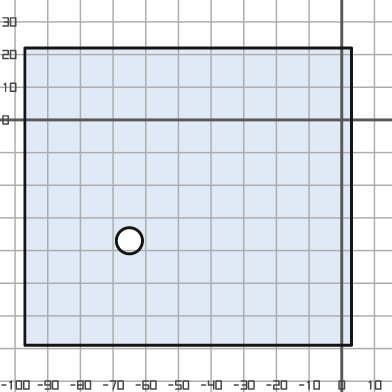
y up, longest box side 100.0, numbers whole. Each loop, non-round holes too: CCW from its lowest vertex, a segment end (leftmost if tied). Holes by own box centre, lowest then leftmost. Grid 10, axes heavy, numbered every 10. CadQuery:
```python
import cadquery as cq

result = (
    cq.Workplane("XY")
    .moveTo(-97.0, -69.0)
    .lineTo(3.0, -69.0)
    .lineTo(3.0, 22.0)
    .lineTo(-97.0, 22.0)
    .close()
    .moveTo(-65.0, -37.0)
    .circle(4.0)
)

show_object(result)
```